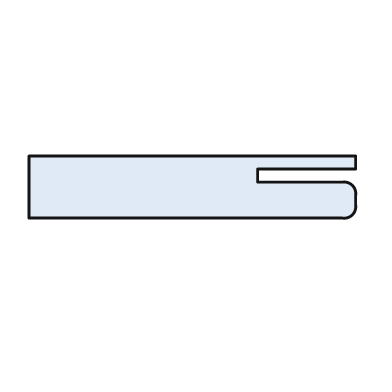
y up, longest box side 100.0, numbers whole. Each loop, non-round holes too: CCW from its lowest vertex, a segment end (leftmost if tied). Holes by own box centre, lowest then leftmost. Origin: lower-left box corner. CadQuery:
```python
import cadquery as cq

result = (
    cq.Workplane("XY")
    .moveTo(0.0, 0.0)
    .lineTo(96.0, 0.0)
    .threePointArc((99.0, 1.0), (100.0, 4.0))
    .lineTo(100.0, 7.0)
    .threePointArc((99.0, 10.0), (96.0, 11.0))
    .lineTo(70.0, 11.0)
    .lineTo(70.0, 15.0)
    .lineTo(100.0, 15.0)
    .lineTo(100.0, 19.0)
    .lineTo(0.0, 19.0)
    .close()
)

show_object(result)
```